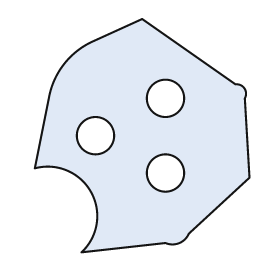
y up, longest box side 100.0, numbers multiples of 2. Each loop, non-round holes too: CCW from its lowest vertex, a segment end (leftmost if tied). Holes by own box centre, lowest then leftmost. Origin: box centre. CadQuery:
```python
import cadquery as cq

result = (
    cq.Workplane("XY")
    .moveTo(-26.0, -50.0)
    .lineTo(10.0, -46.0)
    .threePointArc((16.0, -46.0), (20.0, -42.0))
    .lineTo(46.0, -18.0)
    .lineTo(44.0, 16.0)
    .threePointArc((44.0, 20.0), (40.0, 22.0))
    .lineTo(0.0, 50.0)
    .lineTo(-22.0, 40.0)
    .threePointArc((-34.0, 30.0), (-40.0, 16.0))
    .lineTo(-46.0, -14.0)
    .threePointArc((-22.0, -24.0), (-26.0, -50.0))
    .close()
    .moveTo(10.0, -16.0)
    .circle(8.0)
    .moveTo(-20.0, 0.0)
    .circle(8.0)
    .moveTo(10.0, 16.0)
    .circle(8.0)
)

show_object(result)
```